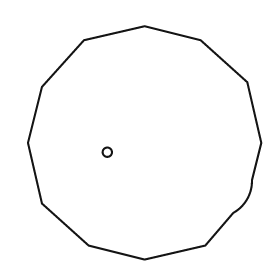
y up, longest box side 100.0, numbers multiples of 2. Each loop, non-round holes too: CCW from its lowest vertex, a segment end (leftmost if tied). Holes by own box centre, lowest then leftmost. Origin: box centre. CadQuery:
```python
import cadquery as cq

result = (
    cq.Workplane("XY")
    .moveTo(0.0, -50.0)
    .lineTo(26.0, -44.0)
    .lineTo(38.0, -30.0)
    .threePointArc((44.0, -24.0), (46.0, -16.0))
    .lineTo(50.0, 0.0)
    .lineTo(44.0, 26.0)
    .lineTo(24.0, 44.0)
    .lineTo(0.0, 50.0)
    .lineTo(-26.0, 44.0)
    .lineTo(-44.0, 24.0)
    .lineTo(-50.0, 0.0)
    .lineTo(-44.0, -26.0)
    .lineTo(-24.0, -44.0)
    .close()
    .moveTo(-16.0, -4.0)
    .circle(2.0)
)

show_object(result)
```